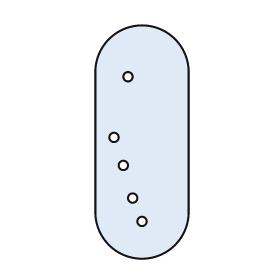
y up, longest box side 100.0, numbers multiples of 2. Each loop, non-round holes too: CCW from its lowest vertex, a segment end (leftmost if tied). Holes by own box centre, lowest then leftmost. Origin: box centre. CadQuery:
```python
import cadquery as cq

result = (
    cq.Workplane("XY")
    .moveTo(-20.0, -30.0)
    .threePointArc((0.0, -50.0), (20.0, -30.0))
    .lineTo(20.0, 30.0)
    .threePointArc((0.0, 50.0), (-20.0, 30.0))
    .close()
    .moveTo(0.0, -34.0)
    .circle(2.0)
    .moveTo(-4.0, -24.0)
    .circle(2.0)
    .moveTo(-8.0, -10.0)
    .circle(2.0)
    .moveTo(-12.0, 2.0)
    .circle(2.0)
    .moveTo(-6.0, 28.0)
    .circle(2.0)
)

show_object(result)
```